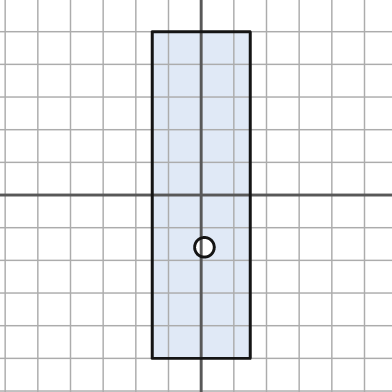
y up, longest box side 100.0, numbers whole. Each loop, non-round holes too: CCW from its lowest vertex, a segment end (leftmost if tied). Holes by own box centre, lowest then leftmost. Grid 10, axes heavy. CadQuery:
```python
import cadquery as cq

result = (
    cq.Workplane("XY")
    .moveTo(-15.0, -50.0)
    .lineTo(15.0, -50.0)
    .lineTo(15.0, 50.0)
    .lineTo(-15.0, 50.0)
    .close()
    .moveTo(1.0, -16.0)
    .circle(3.0)
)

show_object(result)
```